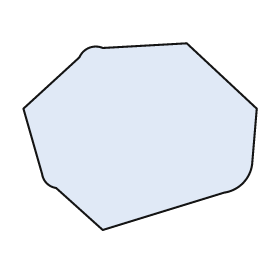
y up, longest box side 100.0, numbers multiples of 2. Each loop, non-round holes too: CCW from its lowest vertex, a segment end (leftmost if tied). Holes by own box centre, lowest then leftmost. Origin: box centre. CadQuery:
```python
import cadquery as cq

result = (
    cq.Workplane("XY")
    .moveTo(-16.0, -40.0)
    .lineTo(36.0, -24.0)
    .threePointArc((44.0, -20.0), (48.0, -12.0))
    .lineTo(50.0, 12.0)
    .lineTo(20.0, 40.0)
    .lineTo(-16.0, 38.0)
    .threePointArc((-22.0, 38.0), (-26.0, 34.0))
    .lineTo(-50.0, 12.0)
    .lineTo(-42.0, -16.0)
    .threePointArc((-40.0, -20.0), (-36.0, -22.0))
    .close()
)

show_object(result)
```